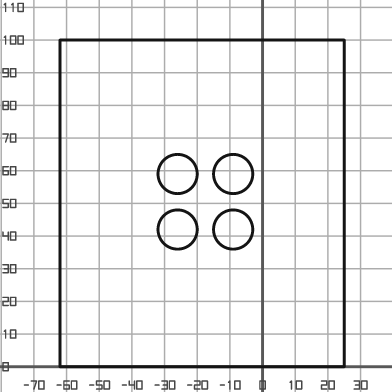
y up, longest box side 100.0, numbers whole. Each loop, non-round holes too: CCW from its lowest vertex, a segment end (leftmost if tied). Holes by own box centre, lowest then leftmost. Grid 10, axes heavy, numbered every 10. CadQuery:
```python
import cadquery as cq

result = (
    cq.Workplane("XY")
    .moveTo(-62.0, 0.0)
    .lineTo(25.0, 0.0)
    .lineTo(25.0, 100.0)
    .lineTo(-62.0, 100.0)
    .close()
    .moveTo(-26.0, 42.0)
    .circle(6.0)
    .moveTo(-9.0, 42.0)
    .circle(6.0)
    .moveTo(-26.0, 59.0)
    .circle(6.0)
    .moveTo(-9.0, 59.0)
    .circle(6.0)
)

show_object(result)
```